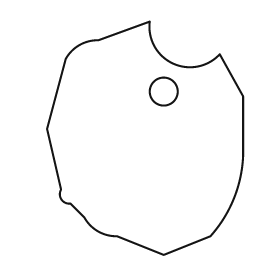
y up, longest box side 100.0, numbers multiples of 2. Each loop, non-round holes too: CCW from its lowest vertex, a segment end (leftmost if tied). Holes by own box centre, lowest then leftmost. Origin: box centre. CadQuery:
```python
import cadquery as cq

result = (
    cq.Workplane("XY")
    .moveTo(8.0, -50.0)
    .lineTo(28.0, -42.0)
    .threePointArc((38.0, -26.0), (42.0, -8.0))
    .lineTo(42.0, 18.0)
    .lineTo(32.0, 36.0)
    .threePointArc((12.0, 32.0), (2.0, 50.0))
    .lineTo(-20.0, 42.0)
    .threePointArc((-28.0, 40.0), (-34.0, 34.0))
    .lineTo(-42.0, 4.0)
    .lineTo(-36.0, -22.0)
    .threePointArc((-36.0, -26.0), (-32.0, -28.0))
    .lineTo(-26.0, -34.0)
    .threePointArc((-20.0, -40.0), (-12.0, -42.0))
    .close()
    .moveTo(8.0, 20.0)
    .circle(6.0)
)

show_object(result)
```